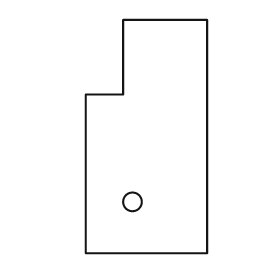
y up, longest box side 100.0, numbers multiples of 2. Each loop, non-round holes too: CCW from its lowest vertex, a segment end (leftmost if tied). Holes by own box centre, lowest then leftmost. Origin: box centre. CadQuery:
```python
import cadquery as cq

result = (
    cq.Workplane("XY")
    .moveTo(-26.0, -50.0)
    .lineTo(26.0, -50.0)
    .lineTo(26.0, 50.0)
    .lineTo(-10.0, 50.0)
    .lineTo(-10.0, 18.0)
    .lineTo(-26.0, 18.0)
    .close()
    .moveTo(-6.0, -28.0)
    .circle(4.0)
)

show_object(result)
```